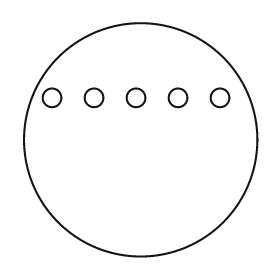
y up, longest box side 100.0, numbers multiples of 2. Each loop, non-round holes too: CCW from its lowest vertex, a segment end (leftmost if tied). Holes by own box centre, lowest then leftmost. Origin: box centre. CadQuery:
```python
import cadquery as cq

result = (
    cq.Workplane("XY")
    .moveTo(0.0, 0.0)
    .circle(50.0)
    .moveTo(-38.0, 18.0)
    .circle(4.0)
    .moveTo(-20.0, 18.0)
    .circle(4.0)
    .moveTo(-2.0, 18.0)
    .circle(4.0)
    .moveTo(16.0, 18.0)
    .circle(4.0)
    .moveTo(34.0, 18.0)
    .circle(4.0)
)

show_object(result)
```